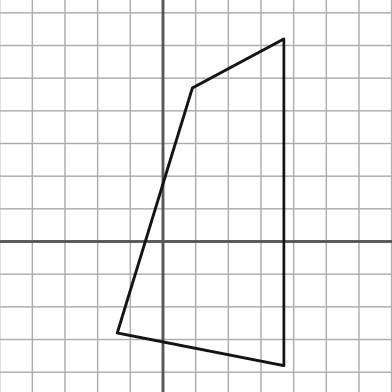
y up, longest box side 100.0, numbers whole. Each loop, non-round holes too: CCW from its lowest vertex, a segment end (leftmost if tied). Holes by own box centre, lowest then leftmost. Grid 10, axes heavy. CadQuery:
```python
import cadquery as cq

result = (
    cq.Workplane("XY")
    .moveTo(37.0, -38.0)
    .lineTo(37.0, 62.0)
    .lineTo(9.0, 47.0)
    .lineTo(-14.0, -28.0)
    .close()
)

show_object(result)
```